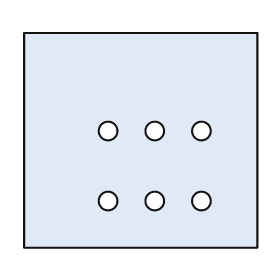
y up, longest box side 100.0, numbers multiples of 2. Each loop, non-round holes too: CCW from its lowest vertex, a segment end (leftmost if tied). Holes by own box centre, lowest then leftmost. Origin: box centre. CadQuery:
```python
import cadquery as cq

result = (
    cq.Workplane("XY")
    .moveTo(-50.0, -46.0)
    .lineTo(50.0, -46.0)
    .lineTo(50.0, 46.0)
    .lineTo(-50.0, 46.0)
    .close()
    .moveTo(-14.0, -26.0)
    .circle(4.0)
    .moveTo(6.0, -26.0)
    .circle(4.0)
    .moveTo(26.0, -26.0)
    .circle(4.0)
    .moveTo(-14.0, 4.0)
    .circle(4.0)
    .moveTo(6.0, 4.0)
    .circle(4.0)
    .moveTo(26.0, 4.0)
    .circle(4.0)
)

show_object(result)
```